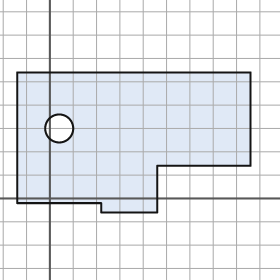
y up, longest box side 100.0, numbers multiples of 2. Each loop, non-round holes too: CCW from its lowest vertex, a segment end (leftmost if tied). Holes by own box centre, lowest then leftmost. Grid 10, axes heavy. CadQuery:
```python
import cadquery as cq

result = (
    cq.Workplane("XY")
    .moveTo(22.0, -6.0)
    .lineTo(46.0, -6.0)
    .lineTo(46.0, 14.0)
    .lineTo(86.0, 14.0)
    .lineTo(86.0, 54.0)
    .lineTo(-14.0, 54.0)
    .lineTo(-14.0, -2.0)
    .lineTo(22.0, -2.0)
    .close()
    .moveTo(4.0, 30.0)
    .circle(6.0)
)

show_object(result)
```